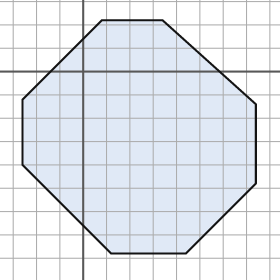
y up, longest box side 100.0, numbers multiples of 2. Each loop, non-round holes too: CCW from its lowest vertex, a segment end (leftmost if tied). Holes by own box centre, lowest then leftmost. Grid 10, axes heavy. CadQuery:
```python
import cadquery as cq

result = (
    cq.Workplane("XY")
    .moveTo(12.0, -78.0)
    .lineTo(44.0, -78.0)
    .lineTo(74.0, -48.0)
    .lineTo(74.0, -14.0)
    .lineTo(34.0, 22.0)
    .lineTo(8.0, 22.0)
    .lineTo(-26.0, -12.0)
    .lineTo(-26.0, -40.0)
    .close()
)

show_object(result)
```